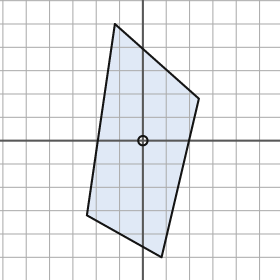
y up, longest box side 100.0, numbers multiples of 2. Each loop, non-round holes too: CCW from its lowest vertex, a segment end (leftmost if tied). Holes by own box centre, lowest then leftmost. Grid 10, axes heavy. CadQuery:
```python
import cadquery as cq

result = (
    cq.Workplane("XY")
    .moveTo(8.0, -50.0)
    .lineTo(24.0, 18.0)
    .lineTo(-12.0, 50.0)
    .lineTo(-24.0, -32.0)
    .close()
    .moveTo(0.0, 0.0)
    .circle(2.0)
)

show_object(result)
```